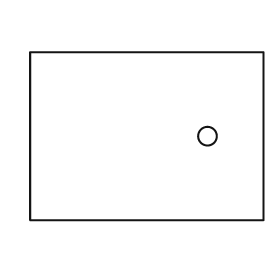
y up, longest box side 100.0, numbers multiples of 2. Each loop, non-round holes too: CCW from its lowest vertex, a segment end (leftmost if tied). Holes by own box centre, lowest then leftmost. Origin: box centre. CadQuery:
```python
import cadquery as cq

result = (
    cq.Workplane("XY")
    .moveTo(-50.0, -36.0)
    .lineTo(50.0, -36.0)
    .lineTo(50.0, 36.0)
    .lineTo(-50.0, 36.0)
    .close()
    .moveTo(26.0, 0.0)
    .circle(4.0)
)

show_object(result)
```